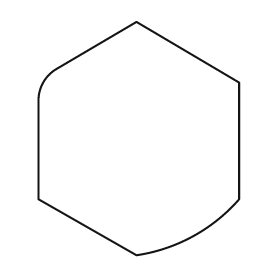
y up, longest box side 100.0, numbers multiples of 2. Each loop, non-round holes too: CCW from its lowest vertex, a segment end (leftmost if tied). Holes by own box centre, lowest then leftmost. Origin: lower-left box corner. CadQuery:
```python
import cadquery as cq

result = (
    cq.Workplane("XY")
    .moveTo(42.0, 0.0)
    .threePointArc((66.0, 8.0), (86.0, 24.0))
    .lineTo(86.0, 74.0)
    .lineTo(42.0, 100.0)
    .lineTo(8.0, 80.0)
    .threePointArc((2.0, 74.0), (0.0, 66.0))
    .lineTo(0.0, 24.0)
    .close()
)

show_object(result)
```